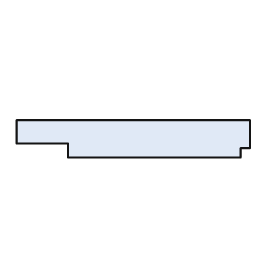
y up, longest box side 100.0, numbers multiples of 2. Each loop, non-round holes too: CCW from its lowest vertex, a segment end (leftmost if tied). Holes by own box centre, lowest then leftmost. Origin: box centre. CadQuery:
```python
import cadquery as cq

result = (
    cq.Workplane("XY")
    .moveTo(-28.0, -8.0)
    .lineTo(46.0, -8.0)
    .lineTo(46.0, -4.0)
    .lineTo(50.0, -4.0)
    .lineTo(50.0, 8.0)
    .lineTo(-50.0, 8.0)
    .lineTo(-50.0, -2.0)
    .lineTo(-28.0, -2.0)
    .close()
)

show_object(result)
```